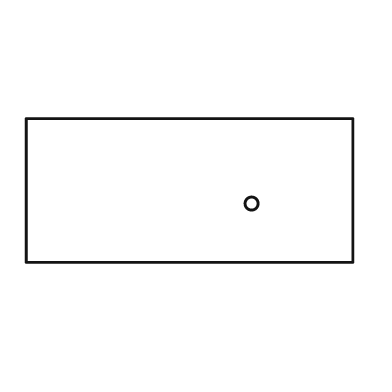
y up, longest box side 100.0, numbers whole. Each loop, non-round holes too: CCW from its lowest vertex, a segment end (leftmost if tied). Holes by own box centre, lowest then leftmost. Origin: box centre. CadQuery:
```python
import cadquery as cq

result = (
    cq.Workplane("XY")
    .moveTo(-50.0, -22.0)
    .lineTo(50.0, -22.0)
    .lineTo(50.0, 22.0)
    .lineTo(-50.0, 22.0)
    .close()
    .moveTo(19.0, -4.0)
    .circle(2.0)
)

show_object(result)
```